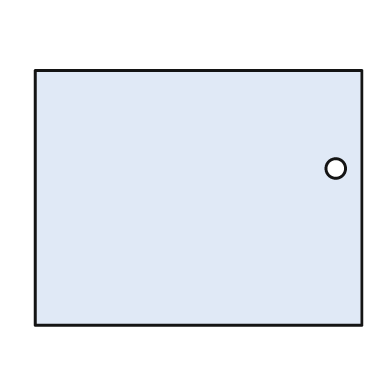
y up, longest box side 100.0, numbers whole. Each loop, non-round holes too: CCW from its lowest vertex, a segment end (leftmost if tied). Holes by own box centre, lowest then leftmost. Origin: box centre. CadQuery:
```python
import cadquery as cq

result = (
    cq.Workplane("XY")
    .moveTo(-50.0, -39.0)
    .lineTo(50.0, -39.0)
    .lineTo(50.0, 39.0)
    .lineTo(-50.0, 39.0)
    .close()
    .moveTo(42.0, 9.0)
    .circle(3.0)
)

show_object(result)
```